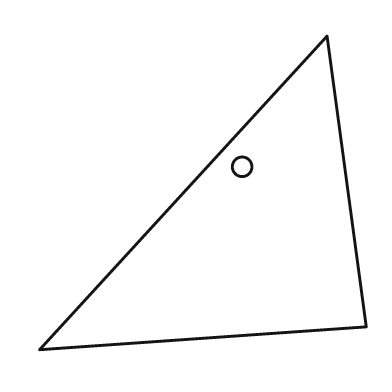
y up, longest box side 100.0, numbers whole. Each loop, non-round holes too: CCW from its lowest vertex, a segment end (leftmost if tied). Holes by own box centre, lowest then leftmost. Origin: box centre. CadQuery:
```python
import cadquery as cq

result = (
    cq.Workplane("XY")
    .moveTo(-50.0, -48.0)
    .lineTo(50.0, -41.0)
    .lineTo(38.0, 48.0)
    .close()
    .moveTo(12.0, 8.0)
    .circle(3.0)
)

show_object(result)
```